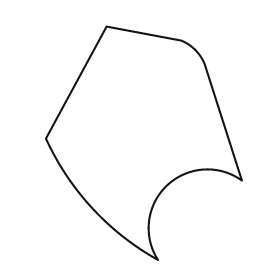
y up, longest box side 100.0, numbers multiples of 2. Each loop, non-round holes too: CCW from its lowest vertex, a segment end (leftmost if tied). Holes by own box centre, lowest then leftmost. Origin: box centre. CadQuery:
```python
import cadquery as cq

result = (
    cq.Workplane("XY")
    .moveTo(6.0, -50.0)
    .threePointArc((10.0, -18.0), (42.0, -16.0))
    .lineTo(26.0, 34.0)
    .threePointArc((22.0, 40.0), (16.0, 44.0))
    .lineTo(-16.0, 50.0)
    .lineTo(-42.0, 2.0)
    .threePointArc((-22.0, -28.0), (6.0, -50.0))
    .close()
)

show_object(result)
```